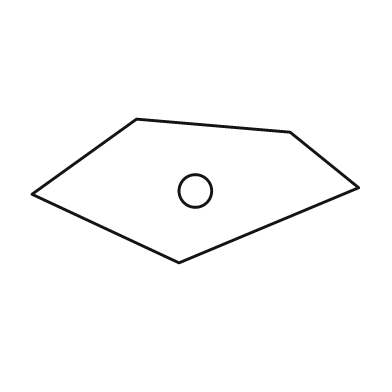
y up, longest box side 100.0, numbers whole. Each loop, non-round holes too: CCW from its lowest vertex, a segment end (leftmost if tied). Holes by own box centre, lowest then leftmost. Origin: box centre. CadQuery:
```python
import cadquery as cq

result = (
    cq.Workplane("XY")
    .moveTo(-5.0, -22.0)
    .lineTo(50.0, 1.0)
    .lineTo(29.0, 18.0)
    .lineTo(-18.0, 22.0)
    .lineTo(-50.0, -1.0)
    .close()
    .moveTo(0.0, 0.0)
    .circle(5.0)
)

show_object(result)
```